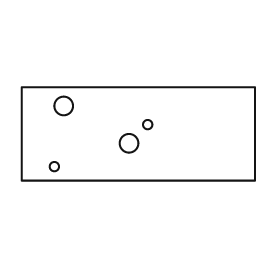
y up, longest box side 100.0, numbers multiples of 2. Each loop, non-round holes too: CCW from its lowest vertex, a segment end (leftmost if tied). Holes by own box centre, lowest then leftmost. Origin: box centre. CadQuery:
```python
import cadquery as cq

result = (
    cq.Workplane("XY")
    .moveTo(-50.0, -20.0)
    .lineTo(50.0, -20.0)
    .lineTo(50.0, 20.0)
    .lineTo(-50.0, 20.0)
    .close()
    .moveTo(-36.0, -14.0)
    .circle(2.0)
    .moveTo(-4.0, -4.0)
    .circle(4.0)
    .moveTo(4.0, 4.0)
    .circle(2.0)
    .moveTo(-32.0, 12.0)
    .circle(4.0)
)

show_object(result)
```